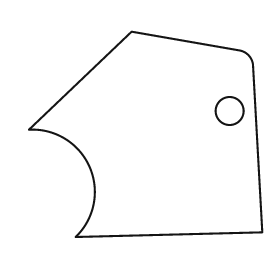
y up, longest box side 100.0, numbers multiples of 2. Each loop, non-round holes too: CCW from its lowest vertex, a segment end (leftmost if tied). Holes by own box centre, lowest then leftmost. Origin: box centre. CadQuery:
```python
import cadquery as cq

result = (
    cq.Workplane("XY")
    .moveTo(-30.0, -44.0)
    .lineTo(50.0, -42.0)
    .lineTo(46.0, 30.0)
    .threePointArc((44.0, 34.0), (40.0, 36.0))
    .lineTo(-6.0, 44.0)
    .lineTo(-50.0, 2.0)
    .threePointArc((-24.0, -14.0), (-30.0, -44.0))
    .close()
    .moveTo(36.0, 10.0)
    .circle(6.0)
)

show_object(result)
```